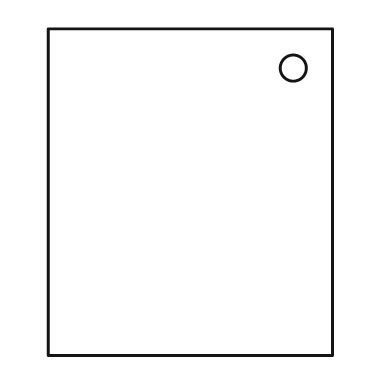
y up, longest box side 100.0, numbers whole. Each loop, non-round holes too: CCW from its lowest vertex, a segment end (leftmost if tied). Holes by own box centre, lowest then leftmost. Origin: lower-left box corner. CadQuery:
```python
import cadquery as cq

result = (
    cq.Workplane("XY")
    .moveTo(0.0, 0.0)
    .lineTo(87.0, 0.0)
    .lineTo(87.0, 100.0)
    .lineTo(0.0, 100.0)
    .close()
    .moveTo(75.0, 88.0)
    .circle(4.0)
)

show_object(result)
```